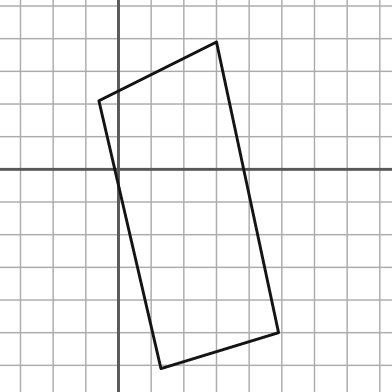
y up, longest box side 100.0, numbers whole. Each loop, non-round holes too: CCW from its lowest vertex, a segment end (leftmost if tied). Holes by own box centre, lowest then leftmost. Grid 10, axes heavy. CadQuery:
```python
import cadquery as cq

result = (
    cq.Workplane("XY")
    .moveTo(13.0, -61.0)
    .lineTo(49.0, -50.0)
    .lineTo(30.0, 39.0)
    .lineTo(-6.0, 21.0)
    .close()
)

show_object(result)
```